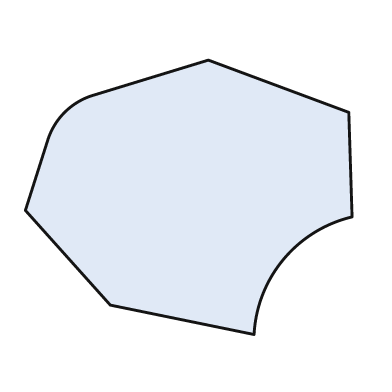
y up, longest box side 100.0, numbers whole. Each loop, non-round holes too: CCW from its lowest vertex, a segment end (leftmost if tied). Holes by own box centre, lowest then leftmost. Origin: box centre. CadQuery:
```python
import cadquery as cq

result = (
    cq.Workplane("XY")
    .moveTo(20.0, -42.0)
    .threePointArc((29.0, -19.0), (50.0, -6.0))
    .lineTo(49.0, 26.0)
    .lineTo(6.0, 42.0)
    .lineTo(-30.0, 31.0)
    .threePointArc((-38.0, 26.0), (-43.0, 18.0))
    .lineTo(-50.0, -4.0)
    .lineTo(-24.0, -33.0)
    .close()
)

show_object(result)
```